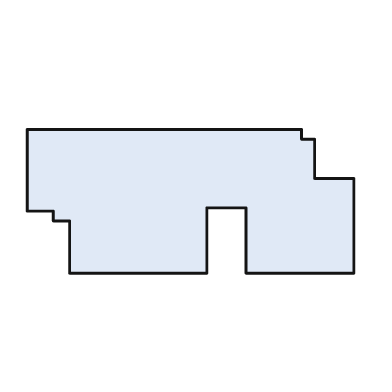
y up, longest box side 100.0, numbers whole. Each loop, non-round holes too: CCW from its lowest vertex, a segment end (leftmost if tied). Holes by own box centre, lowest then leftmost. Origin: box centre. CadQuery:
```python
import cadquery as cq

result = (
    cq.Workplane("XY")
    .moveTo(-37.0, -22.0)
    .lineTo(5.0, -22.0)
    .lineTo(5.0, -2.0)
    .lineTo(17.0, -2.0)
    .lineTo(17.0, -22.0)
    .lineTo(50.0, -22.0)
    .lineTo(50.0, 7.0)
    .lineTo(38.0, 7.0)
    .lineTo(38.0, 19.0)
    .lineTo(34.0, 19.0)
    .lineTo(34.0, 22.0)
    .lineTo(-50.0, 22.0)
    .lineTo(-50.0, -3.0)
    .lineTo(-42.0, -3.0)
    .lineTo(-42.0, -6.0)
    .lineTo(-37.0, -6.0)
    .close()
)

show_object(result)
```